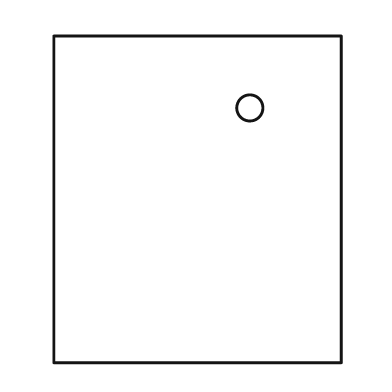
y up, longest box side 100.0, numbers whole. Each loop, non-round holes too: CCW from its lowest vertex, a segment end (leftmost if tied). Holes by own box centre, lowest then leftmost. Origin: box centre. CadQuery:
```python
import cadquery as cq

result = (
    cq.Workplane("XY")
    .moveTo(-44.0, -50.0)
    .lineTo(44.0, -50.0)
    .lineTo(44.0, 50.0)
    .lineTo(-44.0, 50.0)
    .close()
    .moveTo(16.0, 28.0)
    .circle(4.0)
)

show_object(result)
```